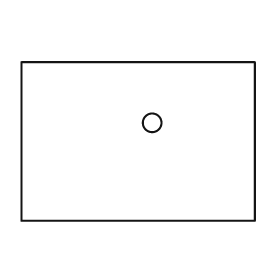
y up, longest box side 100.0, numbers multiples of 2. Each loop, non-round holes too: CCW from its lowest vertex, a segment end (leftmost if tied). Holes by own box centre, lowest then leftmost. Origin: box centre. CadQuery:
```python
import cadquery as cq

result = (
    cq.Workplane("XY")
    .moveTo(-50.0, -34.0)
    .lineTo(50.0, -34.0)
    .lineTo(50.0, 34.0)
    .lineTo(-50.0, 34.0)
    .close()
    .moveTo(6.0, 8.0)
    .circle(4.0)
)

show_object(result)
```